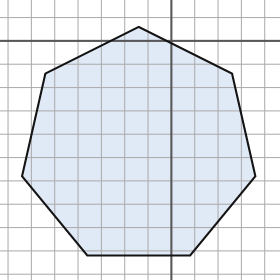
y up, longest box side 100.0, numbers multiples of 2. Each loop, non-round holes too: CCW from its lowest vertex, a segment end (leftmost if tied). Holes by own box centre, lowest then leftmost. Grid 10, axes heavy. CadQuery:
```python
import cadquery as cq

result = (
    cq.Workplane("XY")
    .moveTo(-36.0, -92.0)
    .lineTo(8.0, -92.0)
    .lineTo(36.0, -58.0)
    .lineTo(26.0, -14.0)
    .lineTo(-14.0, 6.0)
    .lineTo(-54.0, -14.0)
    .lineTo(-64.0, -58.0)
    .close()
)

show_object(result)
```